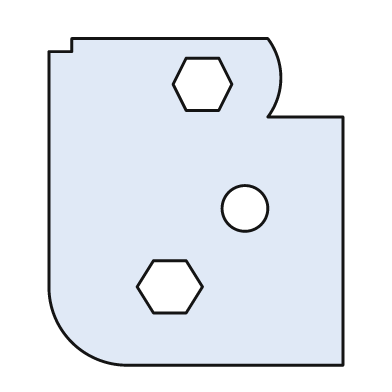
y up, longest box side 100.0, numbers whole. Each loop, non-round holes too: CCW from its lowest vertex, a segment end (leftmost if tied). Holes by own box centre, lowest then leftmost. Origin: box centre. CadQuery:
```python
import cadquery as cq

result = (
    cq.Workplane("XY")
    .moveTo(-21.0, -50.0)
    .lineTo(45.0, -50.0)
    .lineTo(45.0, 26.0)
    .lineTo(22.0, 26.0)
    .threePointArc((26.0, 38.0), (22.0, 50.0))
    .lineTo(-38.0, 50.0)
    .lineTo(-38.0, 46.0)
    .lineTo(-45.0, 46.0)
    .lineTo(-45.0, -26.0)
    .threePointArc((-38.0, -43.0), (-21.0, -50.0))
    .close()
    .moveTo(-13.0, -34.0)
    .lineTo(-3.0, -34.0)
    .lineTo(2.0, -26.0)
    .lineTo(-3.0, -18.0)
    .lineTo(-13.0, -18.0)
    .lineTo(-18.0, -26.0)
    .close()
    .moveTo(15.0, -2.0)
    .circle(7.0)
    .moveTo(-3.0, 28.0)
    .lineTo(7.0, 28.0)
    .lineTo(11.0, 36.0)
    .lineTo(7.0, 44.0)
    .lineTo(-3.0, 44.0)
    .lineTo(-7.0, 36.0)
    .close()
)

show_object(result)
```